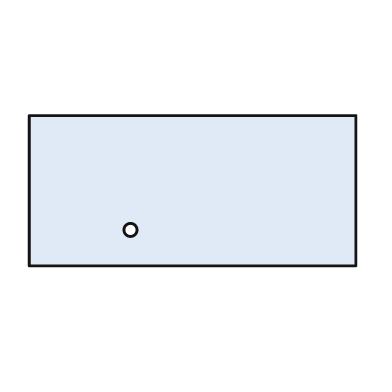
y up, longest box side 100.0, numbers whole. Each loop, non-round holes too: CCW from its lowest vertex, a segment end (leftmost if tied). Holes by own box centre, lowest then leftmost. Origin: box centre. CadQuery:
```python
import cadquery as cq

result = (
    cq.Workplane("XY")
    .moveTo(-50.0, -23.0)
    .lineTo(50.0, -23.0)
    .lineTo(50.0, 23.0)
    .lineTo(-50.0, 23.0)
    .close()
    .moveTo(-19.0, -12.0)
    .circle(2.0)
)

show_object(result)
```